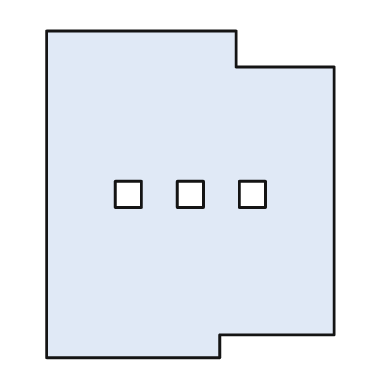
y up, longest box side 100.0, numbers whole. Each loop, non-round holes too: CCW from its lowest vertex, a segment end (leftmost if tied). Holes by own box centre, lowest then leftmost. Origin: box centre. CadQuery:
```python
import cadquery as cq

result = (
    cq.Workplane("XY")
    .moveTo(-44.0, -50.0)
    .lineTo(9.0, -50.0)
    .lineTo(9.0, -43.0)
    .lineTo(44.0, -43.0)
    .lineTo(44.0, 39.0)
    .lineTo(14.0, 39.0)
    .lineTo(14.0, 50.0)
    .lineTo(-44.0, 50.0)
    .close()
    .moveTo(-23.0, -4.0)
    .lineTo(-15.0, -4.0)
    .lineTo(-15.0, 4.0)
    .lineTo(-23.0, 4.0)
    .close()
    .moveTo(-4.0, -4.0)
    .lineTo(4.0, -4.0)
    .lineTo(4.0, 4.0)
    .lineTo(-4.0, 4.0)
    .close()
    .moveTo(15.0, -4.0)
    .lineTo(23.0, -4.0)
    .lineTo(23.0, 4.0)
    .lineTo(15.0, 4.0)
    .close()
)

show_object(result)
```